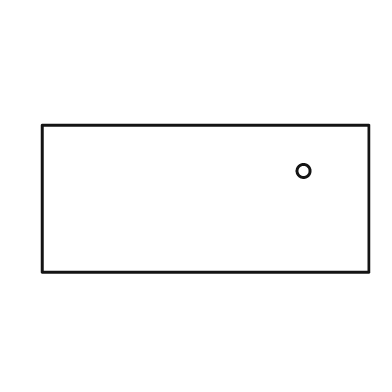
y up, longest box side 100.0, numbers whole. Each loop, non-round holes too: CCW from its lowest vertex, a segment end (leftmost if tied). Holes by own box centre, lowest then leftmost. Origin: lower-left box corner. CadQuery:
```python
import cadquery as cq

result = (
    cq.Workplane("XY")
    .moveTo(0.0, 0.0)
    .lineTo(100.0, 0.0)
    .lineTo(100.0, 45.0)
    .lineTo(0.0, 45.0)
    .close()
    .moveTo(80.0, 31.0)
    .circle(2.0)
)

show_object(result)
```